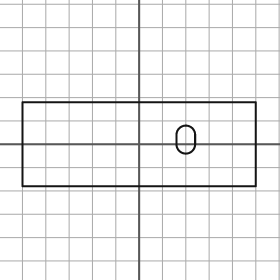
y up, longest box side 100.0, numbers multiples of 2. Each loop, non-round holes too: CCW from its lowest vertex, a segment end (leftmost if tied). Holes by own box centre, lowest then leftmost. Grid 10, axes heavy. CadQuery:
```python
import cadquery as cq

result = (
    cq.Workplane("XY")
    .moveTo(-50.0, -18.0)
    .lineTo(50.0, -18.0)
    .lineTo(50.0, 18.0)
    .lineTo(-50.0, 18.0)
    .close()
    .moveTo(16.0, 0.0)
    .threePointArc((20.0, -4.0), (24.0, 0.0))
    .lineTo(24.0, 4.0)
    .threePointArc((20.0, 8.0), (16.0, 4.0))
    .close()
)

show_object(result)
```